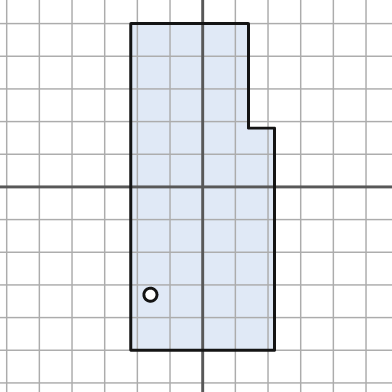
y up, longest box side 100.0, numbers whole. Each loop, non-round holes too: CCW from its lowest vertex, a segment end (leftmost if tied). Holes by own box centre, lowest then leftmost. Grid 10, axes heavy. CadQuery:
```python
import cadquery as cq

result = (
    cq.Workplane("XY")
    .moveTo(-22.0, -50.0)
    .lineTo(22.0, -50.0)
    .lineTo(22.0, 18.0)
    .lineTo(14.0, 18.0)
    .lineTo(14.0, 50.0)
    .lineTo(-22.0, 50.0)
    .close()
    .moveTo(-16.0, -33.0)
    .circle(2.0)
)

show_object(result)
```